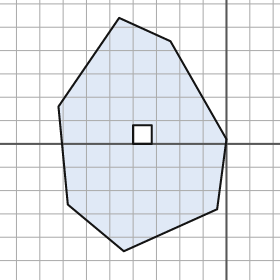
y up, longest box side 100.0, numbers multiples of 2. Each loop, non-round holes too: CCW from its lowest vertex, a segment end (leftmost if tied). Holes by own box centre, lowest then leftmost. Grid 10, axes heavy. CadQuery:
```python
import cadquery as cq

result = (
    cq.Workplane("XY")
    .moveTo(-44.0, -46.0)
    .lineTo(-4.0, -28.0)
    .lineTo(0.0, 2.0)
    .lineTo(-24.0, 44.0)
    .lineTo(-46.0, 54.0)
    .lineTo(-72.0, 16.0)
    .lineTo(-68.0, -26.0)
    .close()
    .moveTo(-40.0, 0.0)
    .lineTo(-32.0, 0.0)
    .lineTo(-32.0, 8.0)
    .lineTo(-40.0, 8.0)
    .close()
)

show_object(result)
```